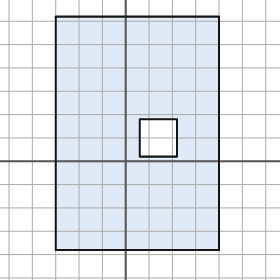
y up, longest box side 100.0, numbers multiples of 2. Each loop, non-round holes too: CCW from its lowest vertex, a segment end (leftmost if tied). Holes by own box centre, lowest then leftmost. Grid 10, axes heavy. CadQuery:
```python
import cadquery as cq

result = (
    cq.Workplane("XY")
    .moveTo(-30.0, -38.0)
    .lineTo(40.0, -38.0)
    .lineTo(40.0, 62.0)
    .lineTo(-30.0, 62.0)
    .close()
    .moveTo(6.0, 2.0)
    .lineTo(22.0, 2.0)
    .lineTo(22.0, 18.0)
    .lineTo(6.0, 18.0)
    .close()
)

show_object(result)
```